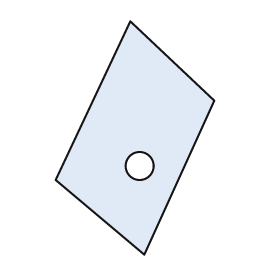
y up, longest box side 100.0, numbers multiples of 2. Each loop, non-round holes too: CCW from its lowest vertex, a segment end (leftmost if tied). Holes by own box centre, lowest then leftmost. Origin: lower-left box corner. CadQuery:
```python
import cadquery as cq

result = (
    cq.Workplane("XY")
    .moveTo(38.0, 0.0)
    .lineTo(68.0, 66.0)
    .lineTo(32.0, 100.0)
    .lineTo(0.0, 32.0)
    .close()
    .moveTo(36.0, 38.0)
    .circle(6.0)
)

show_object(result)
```